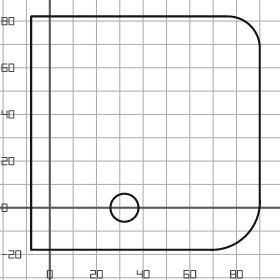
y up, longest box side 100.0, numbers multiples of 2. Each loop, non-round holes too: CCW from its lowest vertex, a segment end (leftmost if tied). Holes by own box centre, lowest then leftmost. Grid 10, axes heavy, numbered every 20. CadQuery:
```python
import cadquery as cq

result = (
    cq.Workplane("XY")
    .moveTo(-8.0, -18.0)
    .lineTo(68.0, -18.0)
    .threePointArc((84.0, -12.0), (90.0, 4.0))
    .lineTo(90.0, 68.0)
    .threePointArc((86.0, 78.0), (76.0, 82.0))
    .lineTo(-8.0, 82.0)
    .close()
    .moveTo(32.0, 0.0)
    .circle(6.0)
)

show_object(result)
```